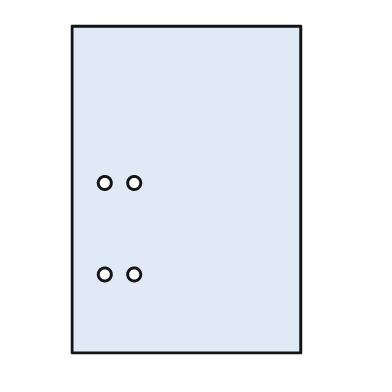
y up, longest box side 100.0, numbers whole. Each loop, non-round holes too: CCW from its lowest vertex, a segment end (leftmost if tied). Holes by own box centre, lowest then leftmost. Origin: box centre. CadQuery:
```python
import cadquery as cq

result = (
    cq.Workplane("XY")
    .moveTo(-35.0, -50.0)
    .lineTo(35.0, -50.0)
    .lineTo(35.0, 50.0)
    .lineTo(-35.0, 50.0)
    .close()
    .moveTo(-25.0, -26.0)
    .circle(2.0)
    .moveTo(-16.0, -26.0)
    .circle(2.0)
    .moveTo(-25.0, 2.0)
    .circle(2.0)
    .moveTo(-16.0, 2.0)
    .circle(2.0)
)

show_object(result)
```